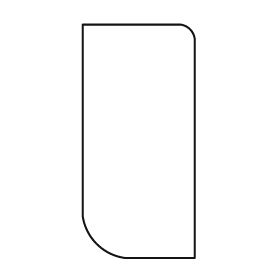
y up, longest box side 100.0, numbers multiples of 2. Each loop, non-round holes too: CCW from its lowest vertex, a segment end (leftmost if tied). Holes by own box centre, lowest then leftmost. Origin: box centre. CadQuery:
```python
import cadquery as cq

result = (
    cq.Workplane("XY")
    .moveTo(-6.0, -50.0)
    .lineTo(24.0, -50.0)
    .lineTo(24.0, 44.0)
    .threePointArc((22.0, 48.0), (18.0, 50.0))
    .lineTo(-24.0, 50.0)
    .lineTo(-24.0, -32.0)
    .threePointArc((-18.0, -44.0), (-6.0, -50.0))
    .close()
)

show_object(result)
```